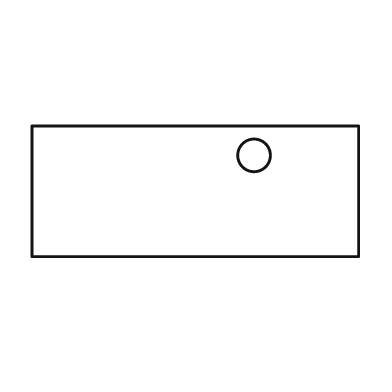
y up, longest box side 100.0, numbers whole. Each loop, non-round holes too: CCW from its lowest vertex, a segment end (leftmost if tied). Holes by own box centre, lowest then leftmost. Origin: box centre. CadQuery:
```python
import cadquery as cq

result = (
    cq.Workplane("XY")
    .moveTo(-50.0, -20.0)
    .lineTo(50.0, -20.0)
    .lineTo(50.0, 20.0)
    .lineTo(-50.0, 20.0)
    .close()
    .moveTo(18.0, 11.0)
    .circle(5.0)
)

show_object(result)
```